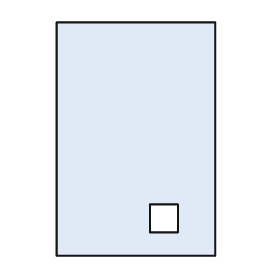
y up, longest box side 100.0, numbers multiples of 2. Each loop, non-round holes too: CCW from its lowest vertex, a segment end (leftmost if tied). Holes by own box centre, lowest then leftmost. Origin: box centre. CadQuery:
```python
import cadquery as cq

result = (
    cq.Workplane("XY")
    .moveTo(-34.0, -50.0)
    .lineTo(34.0, -50.0)
    .lineTo(34.0, 50.0)
    .lineTo(-34.0, 50.0)
    .close()
    .moveTo(6.0, -40.0)
    .lineTo(18.0, -40.0)
    .lineTo(18.0, -28.0)
    .lineTo(6.0, -28.0)
    .close()
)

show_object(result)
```